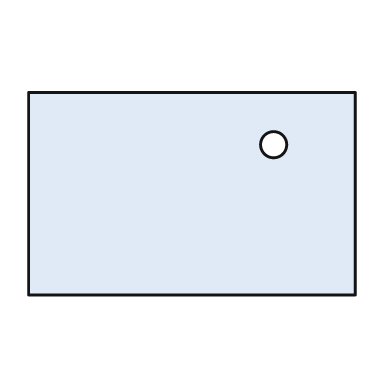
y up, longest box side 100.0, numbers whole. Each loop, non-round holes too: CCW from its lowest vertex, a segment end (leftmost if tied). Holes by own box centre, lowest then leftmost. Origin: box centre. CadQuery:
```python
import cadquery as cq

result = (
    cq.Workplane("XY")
    .moveTo(-50.0, -31.0)
    .lineTo(50.0, -31.0)
    .lineTo(50.0, 31.0)
    .lineTo(-50.0, 31.0)
    .close()
    .moveTo(25.0, 15.0)
    .circle(4.0)
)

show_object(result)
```